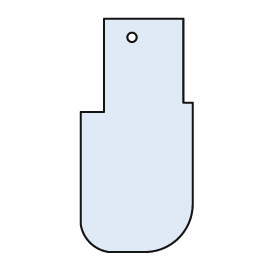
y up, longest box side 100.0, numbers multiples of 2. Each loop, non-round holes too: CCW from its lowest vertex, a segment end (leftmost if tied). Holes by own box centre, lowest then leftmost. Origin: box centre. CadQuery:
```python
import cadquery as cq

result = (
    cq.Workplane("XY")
    .moveTo(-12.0, -50.0)
    .lineTo(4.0, -50.0)
    .threePointArc((18.0, -44.0), (24.0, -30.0))
    .lineTo(24.0, 14.0)
    .lineTo(20.0, 14.0)
    .lineTo(20.0, 50.0)
    .lineTo(-14.0, 50.0)
    .lineTo(-14.0, 10.0)
    .lineTo(-24.0, 10.0)
    .lineTo(-24.0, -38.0)
    .threePointArc((-20.0, -46.0), (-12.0, -50.0))
    .close()
    .moveTo(-2.0, 42.0)
    .circle(2.0)
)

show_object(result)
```